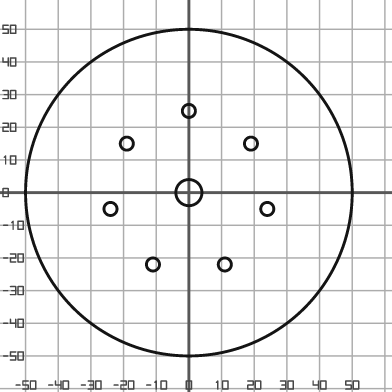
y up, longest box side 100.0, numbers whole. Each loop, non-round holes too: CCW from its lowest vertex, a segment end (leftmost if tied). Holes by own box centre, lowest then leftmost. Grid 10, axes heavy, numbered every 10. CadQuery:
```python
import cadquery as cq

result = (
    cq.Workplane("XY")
    .moveTo(0.0, 0.0)
    .circle(50.0)
    .moveTo(-11.0, -22.0)
    .circle(2.0)
    .moveTo(11.0, -22.0)
    .circle(2.0)
    .moveTo(-24.0, -5.0)
    .circle(2.0)
    .moveTo(24.0, -5.0)
    .circle(2.0)
    .moveTo(0.0, 0.0)
    .circle(4.0)
    .moveTo(-19.0, 15.0)
    .circle(2.0)
    .moveTo(19.0, 15.0)
    .circle(2.0)
    .moveTo(0.0, 25.0)
    .circle(2.0)
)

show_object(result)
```